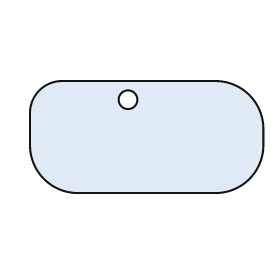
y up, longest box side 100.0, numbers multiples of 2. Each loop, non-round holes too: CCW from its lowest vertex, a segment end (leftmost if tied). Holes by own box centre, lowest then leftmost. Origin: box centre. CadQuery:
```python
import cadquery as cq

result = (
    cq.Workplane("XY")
    .moveTo(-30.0, -24.0)
    .lineTo(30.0, -24.0)
    .threePointArc((44.0, -18.0), (50.0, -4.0))
    .lineTo(50.0, 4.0)
    .threePointArc((44.0, 18.0), (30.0, 24.0))
    .lineTo(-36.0, 24.0)
    .threePointArc((-46.0, 20.0), (-50.0, 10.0))
    .lineTo(-50.0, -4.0)
    .threePointArc((-44.0, -18.0), (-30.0, -24.0))
    .close()
    .moveTo(-8.0, 16.0)
    .circle(4.0)
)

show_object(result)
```